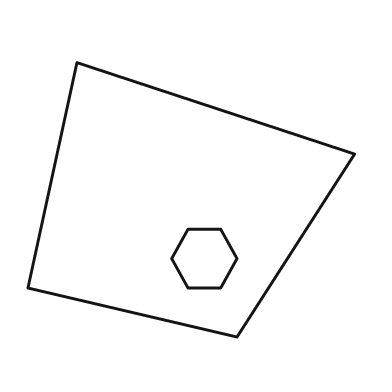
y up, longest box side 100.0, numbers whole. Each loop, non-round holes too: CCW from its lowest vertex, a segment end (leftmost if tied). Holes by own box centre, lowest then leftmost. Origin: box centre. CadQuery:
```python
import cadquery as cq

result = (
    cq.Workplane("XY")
    .moveTo(14.0, -42.0)
    .lineTo(50.0, 14.0)
    .lineTo(-35.0, 42.0)
    .lineTo(-50.0, -27.0)
    .close()
    .moveTo(-1.0, -27.0)
    .lineTo(9.0, -27.0)
    .lineTo(14.0, -18.0)
    .lineTo(9.0, -9.0)
    .lineTo(-1.0, -9.0)
    .lineTo(-6.0, -18.0)
    .close()
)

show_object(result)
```